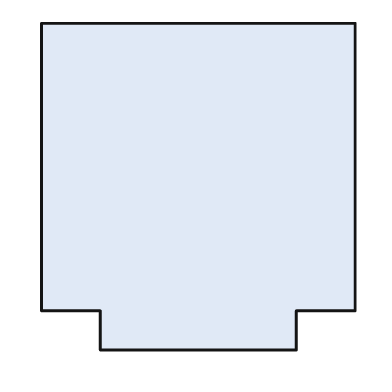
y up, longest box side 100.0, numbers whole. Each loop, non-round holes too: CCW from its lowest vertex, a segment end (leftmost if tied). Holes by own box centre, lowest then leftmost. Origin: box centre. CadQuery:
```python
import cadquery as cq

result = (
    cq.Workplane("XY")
    .moveTo(-30.0, -50.0)
    .lineTo(30.0, -50.0)
    .lineTo(30.0, -38.0)
    .lineTo(48.0, -38.0)
    .lineTo(48.0, 50.0)
    .lineTo(-48.0, 50.0)
    .lineTo(-48.0, -38.0)
    .lineTo(-30.0, -38.0)
    .close()
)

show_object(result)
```